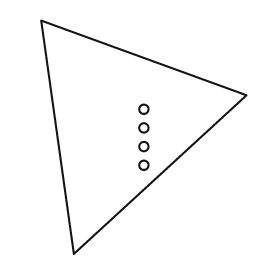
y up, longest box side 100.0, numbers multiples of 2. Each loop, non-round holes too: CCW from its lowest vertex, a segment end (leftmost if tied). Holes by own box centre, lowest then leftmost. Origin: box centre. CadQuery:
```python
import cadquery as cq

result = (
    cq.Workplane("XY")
    .moveTo(-30.0, -50.0)
    .lineTo(44.0, 18.0)
    .lineTo(-44.0, 50.0)
    .close()
    .moveTo(0.0, -12.0)
    .circle(2.0)
    .moveTo(0.0, -4.0)
    .circle(2.0)
    .moveTo(0.0, 4.0)
    .circle(2.0)
    .moveTo(0.0, 12.0)
    .circle(2.0)
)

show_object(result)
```